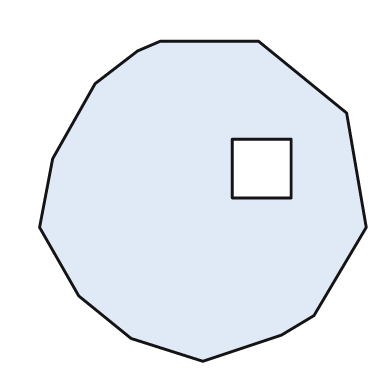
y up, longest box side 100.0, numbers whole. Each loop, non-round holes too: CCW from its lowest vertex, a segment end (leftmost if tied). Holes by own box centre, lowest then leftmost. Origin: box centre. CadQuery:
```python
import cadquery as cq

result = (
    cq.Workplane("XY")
    .moveTo(0.0, -49.0)
    .lineTo(24.0, -41.0)
    .lineTo(34.0, -35.0)
    .lineTo(50.0, -8.0)
    .lineTo(44.0, 27.0)
    .lineTo(17.0, 49.0)
    .lineTo(-13.0, 49.0)
    .lineTo(-20.0, 46.0)
    .lineTo(-33.0, 36.0)
    .lineTo(-46.0, 13.0)
    .lineTo(-50.0, -8.0)
    .lineTo(-38.0, -29.0)
    .lineTo(-22.0, -42.0)
    .close()
    .moveTo(9.0, 1.0)
    .lineTo(27.0, 1.0)
    .lineTo(27.0, 19.0)
    .lineTo(9.0, 19.0)
    .close()
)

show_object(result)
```